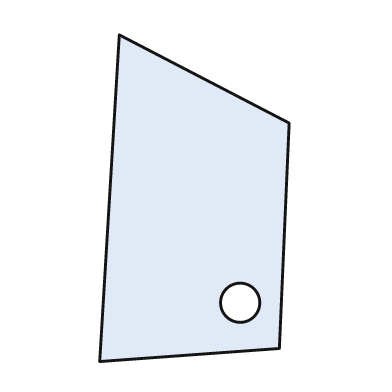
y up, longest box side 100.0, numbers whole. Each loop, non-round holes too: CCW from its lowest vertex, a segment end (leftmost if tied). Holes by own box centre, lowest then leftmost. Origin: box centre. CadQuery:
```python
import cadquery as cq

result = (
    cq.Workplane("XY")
    .moveTo(-29.0, -50.0)
    .lineTo(26.0, -46.0)
    .lineTo(29.0, 23.0)
    .lineTo(-23.0, 50.0)
    .close()
    .moveTo(14.0, -32.0)
    .circle(6.0)
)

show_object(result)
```